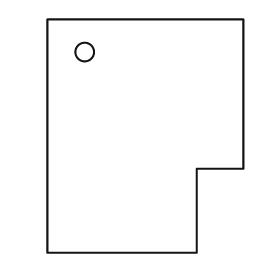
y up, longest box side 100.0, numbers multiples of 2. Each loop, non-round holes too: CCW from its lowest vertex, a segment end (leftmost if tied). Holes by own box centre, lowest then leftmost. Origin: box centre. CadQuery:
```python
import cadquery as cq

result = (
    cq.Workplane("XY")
    .moveTo(-42.0, -50.0)
    .lineTo(22.0, -50.0)
    .lineTo(22.0, -14.0)
    .lineTo(42.0, -14.0)
    .lineTo(42.0, 50.0)
    .lineTo(-42.0, 50.0)
    .close()
    .moveTo(-26.0, 36.0)
    .circle(4.0)
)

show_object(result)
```